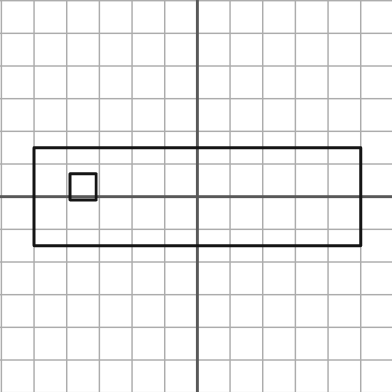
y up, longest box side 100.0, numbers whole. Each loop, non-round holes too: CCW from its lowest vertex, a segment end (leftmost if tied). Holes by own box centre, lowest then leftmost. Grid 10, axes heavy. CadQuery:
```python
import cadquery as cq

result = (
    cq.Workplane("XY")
    .moveTo(-50.0, -15.0)
    .lineTo(50.0, -15.0)
    .lineTo(50.0, 15.0)
    .lineTo(-50.0, 15.0)
    .close()
    .moveTo(-39.0, -1.0)
    .lineTo(-31.0, -1.0)
    .lineTo(-31.0, 7.0)
    .lineTo(-39.0, 7.0)
    .close()
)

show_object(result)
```